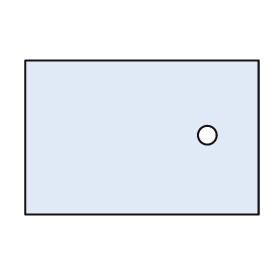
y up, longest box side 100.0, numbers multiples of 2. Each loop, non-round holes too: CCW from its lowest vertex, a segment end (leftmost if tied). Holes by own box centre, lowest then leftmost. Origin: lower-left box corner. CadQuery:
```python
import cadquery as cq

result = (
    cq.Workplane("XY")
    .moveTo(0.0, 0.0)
    .lineTo(100.0, 0.0)
    .lineTo(100.0, 66.0)
    .lineTo(0.0, 66.0)
    .close()
    .moveTo(78.0, 34.0)
    .circle(4.0)
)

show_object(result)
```